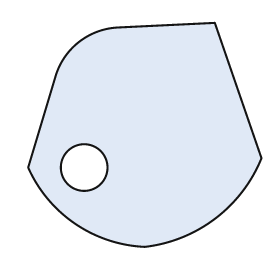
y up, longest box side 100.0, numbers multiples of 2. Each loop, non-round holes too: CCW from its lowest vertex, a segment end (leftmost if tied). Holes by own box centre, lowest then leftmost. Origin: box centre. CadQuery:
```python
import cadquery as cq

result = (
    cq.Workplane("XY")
    .moveTo(0.0, -48.0)
    .threePointArc((30.0, -36.0), (50.0, -10.0))
    .lineTo(30.0, 48.0)
    .lineTo(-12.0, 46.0)
    .threePointArc((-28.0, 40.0), (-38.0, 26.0))
    .lineTo(-50.0, -14.0)
    .threePointArc((-30.0, -38.0), (0.0, -48.0))
    .close()
    .moveTo(-26.0, -14.0)
    .circle(10.0)
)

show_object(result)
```